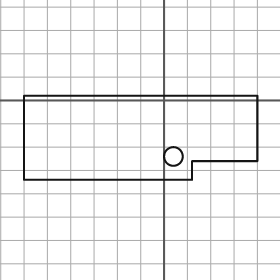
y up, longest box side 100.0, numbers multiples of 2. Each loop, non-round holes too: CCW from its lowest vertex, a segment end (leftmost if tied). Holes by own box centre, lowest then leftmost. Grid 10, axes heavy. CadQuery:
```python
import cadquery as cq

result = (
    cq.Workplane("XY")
    .moveTo(-60.0, -34.0)
    .lineTo(12.0, -34.0)
    .lineTo(12.0, -26.0)
    .lineTo(40.0, -26.0)
    .lineTo(40.0, 2.0)
    .lineTo(-60.0, 2.0)
    .close()
    .moveTo(4.0, -24.0)
    .circle(4.0)
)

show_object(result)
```